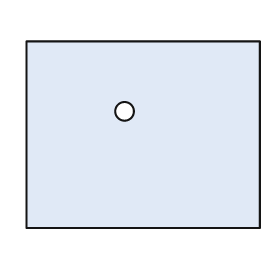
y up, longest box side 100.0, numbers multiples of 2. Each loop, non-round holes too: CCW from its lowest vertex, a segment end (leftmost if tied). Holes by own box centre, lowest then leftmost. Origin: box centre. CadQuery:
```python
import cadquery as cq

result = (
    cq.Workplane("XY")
    .moveTo(-50.0, -40.0)
    .lineTo(50.0, -40.0)
    .lineTo(50.0, 40.0)
    .lineTo(-50.0, 40.0)
    .close()
    .moveTo(-8.0, 10.0)
    .circle(4.0)
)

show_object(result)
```